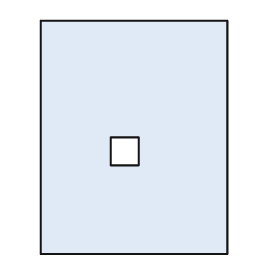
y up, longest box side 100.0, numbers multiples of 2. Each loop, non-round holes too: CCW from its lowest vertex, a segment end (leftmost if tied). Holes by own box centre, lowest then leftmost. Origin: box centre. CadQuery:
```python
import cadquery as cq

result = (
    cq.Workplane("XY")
    .moveTo(-40.0, -50.0)
    .lineTo(40.0, -50.0)
    .lineTo(40.0, 50.0)
    .lineTo(-40.0, 50.0)
    .close()
    .moveTo(-10.0, -12.0)
    .lineTo(2.0, -12.0)
    .lineTo(2.0, 0.0)
    .lineTo(-10.0, 0.0)
    .close()
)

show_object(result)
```